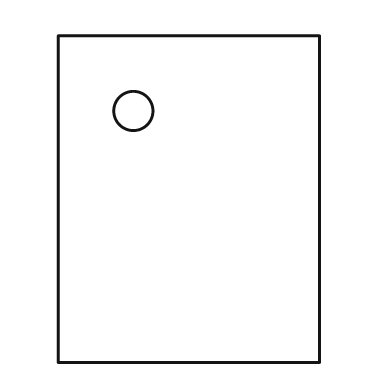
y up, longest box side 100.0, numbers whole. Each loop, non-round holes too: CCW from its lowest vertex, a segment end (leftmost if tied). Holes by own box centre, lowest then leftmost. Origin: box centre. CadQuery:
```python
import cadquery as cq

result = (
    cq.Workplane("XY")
    .moveTo(-40.0, -50.0)
    .lineTo(40.0, -50.0)
    .lineTo(40.0, 50.0)
    .lineTo(-40.0, 50.0)
    .close()
    .moveTo(-17.0, 27.0)
    .circle(6.0)
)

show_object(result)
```